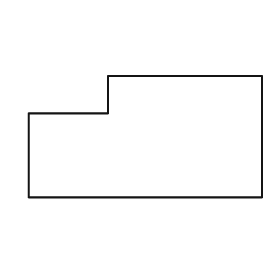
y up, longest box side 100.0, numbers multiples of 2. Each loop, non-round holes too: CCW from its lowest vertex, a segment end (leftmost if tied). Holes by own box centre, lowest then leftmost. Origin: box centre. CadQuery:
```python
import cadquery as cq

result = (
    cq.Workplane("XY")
    .moveTo(-50.0, -26.0)
    .lineTo(50.0, -26.0)
    .lineTo(50.0, 26.0)
    .lineTo(-16.0, 26.0)
    .lineTo(-16.0, 10.0)
    .lineTo(-50.0, 10.0)
    .close()
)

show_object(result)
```